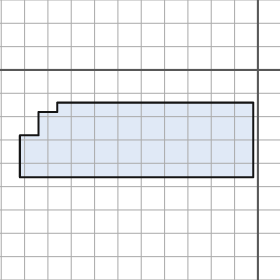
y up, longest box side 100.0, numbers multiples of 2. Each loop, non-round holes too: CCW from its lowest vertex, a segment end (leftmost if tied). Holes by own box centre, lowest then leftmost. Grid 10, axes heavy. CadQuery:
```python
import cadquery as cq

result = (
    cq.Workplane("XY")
    .moveTo(-102.0, -46.0)
    .lineTo(-2.0, -46.0)
    .lineTo(-2.0, -14.0)
    .lineTo(-86.0, -14.0)
    .lineTo(-86.0, -18.0)
    .lineTo(-94.0, -18.0)
    .lineTo(-94.0, -28.0)
    .lineTo(-102.0, -28.0)
    .close()
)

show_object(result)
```